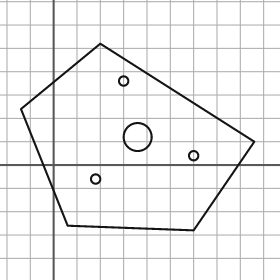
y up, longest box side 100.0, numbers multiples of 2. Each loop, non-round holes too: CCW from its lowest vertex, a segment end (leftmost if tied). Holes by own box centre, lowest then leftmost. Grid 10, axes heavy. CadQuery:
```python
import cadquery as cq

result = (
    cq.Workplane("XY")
    .moveTo(60.0, -28.0)
    .lineTo(86.0, 10.0)
    .lineTo(20.0, 52.0)
    .lineTo(-14.0, 24.0)
    .lineTo(6.0, -26.0)
    .close()
    .moveTo(18.0, -6.0)
    .circle(2.0)
    .moveTo(60.0, 4.0)
    .circle(2.0)
    .moveTo(36.0, 12.0)
    .circle(6.0)
    .moveTo(30.0, 36.0)
    .circle(2.0)
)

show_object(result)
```